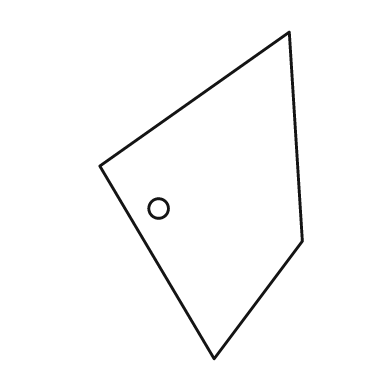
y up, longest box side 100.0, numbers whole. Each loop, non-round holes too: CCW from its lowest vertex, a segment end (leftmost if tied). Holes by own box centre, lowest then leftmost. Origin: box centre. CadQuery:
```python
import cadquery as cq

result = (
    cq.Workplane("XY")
    .moveTo(4.0, -50.0)
    .lineTo(31.0, -14.0)
    .lineTo(27.0, 50.0)
    .lineTo(-31.0, 9.0)
    .close()
    .moveTo(-13.0, -4.0)
    .circle(3.0)
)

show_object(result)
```